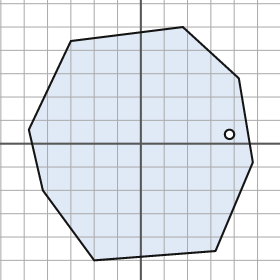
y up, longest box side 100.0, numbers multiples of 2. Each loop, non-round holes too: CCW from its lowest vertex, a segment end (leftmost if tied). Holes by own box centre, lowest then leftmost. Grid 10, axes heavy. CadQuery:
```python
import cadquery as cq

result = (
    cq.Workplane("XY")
    .moveTo(-20.0, -50.0)
    .lineTo(32.0, -46.0)
    .lineTo(48.0, -8.0)
    .lineTo(42.0, 28.0)
    .lineTo(18.0, 50.0)
    .lineTo(-30.0, 44.0)
    .lineTo(-48.0, 6.0)
    .lineTo(-42.0, -20.0)
    .close()
    .moveTo(38.0, 4.0)
    .circle(2.0)
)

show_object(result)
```